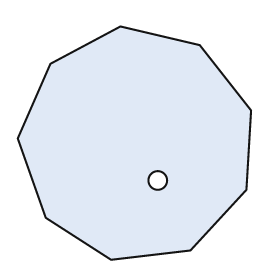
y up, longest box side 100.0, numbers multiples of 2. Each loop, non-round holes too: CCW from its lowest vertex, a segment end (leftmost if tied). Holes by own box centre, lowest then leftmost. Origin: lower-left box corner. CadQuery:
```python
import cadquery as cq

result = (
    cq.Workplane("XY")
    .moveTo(40.0, 0.0)
    .lineTo(74.0, 4.0)
    .lineTo(98.0, 30.0)
    .lineTo(100.0, 64.0)
    .lineTo(78.0, 92.0)
    .lineTo(44.0, 100.0)
    .lineTo(14.0, 84.0)
    .lineTo(0.0, 52.0)
    .lineTo(12.0, 18.0)
    .close()
    .moveTo(60.0, 34.0)
    .circle(4.0)
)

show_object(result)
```